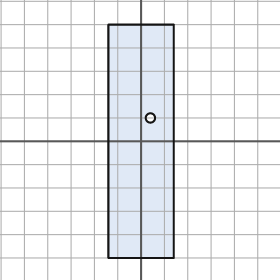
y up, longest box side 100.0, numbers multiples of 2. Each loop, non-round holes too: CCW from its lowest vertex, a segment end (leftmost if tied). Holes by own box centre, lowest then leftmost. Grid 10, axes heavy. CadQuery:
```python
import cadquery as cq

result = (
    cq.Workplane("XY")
    .moveTo(-14.0, -50.0)
    .lineTo(14.0, -50.0)
    .lineTo(14.0, 50.0)
    .lineTo(-14.0, 50.0)
    .close()
    .moveTo(4.0, 10.0)
    .circle(2.0)
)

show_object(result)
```